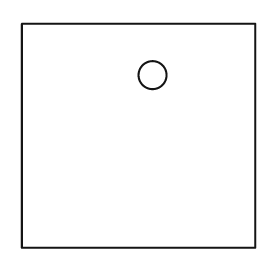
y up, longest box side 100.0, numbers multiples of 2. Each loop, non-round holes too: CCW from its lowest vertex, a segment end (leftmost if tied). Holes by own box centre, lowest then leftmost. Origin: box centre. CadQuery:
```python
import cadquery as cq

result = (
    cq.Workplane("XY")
    .moveTo(-50.0, -48.0)
    .lineTo(50.0, -48.0)
    .lineTo(50.0, 48.0)
    .lineTo(-50.0, 48.0)
    .close()
    .moveTo(6.0, 26.0)
    .circle(6.0)
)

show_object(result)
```